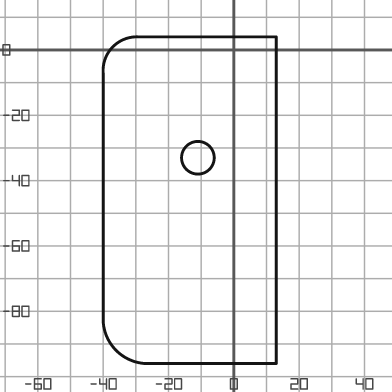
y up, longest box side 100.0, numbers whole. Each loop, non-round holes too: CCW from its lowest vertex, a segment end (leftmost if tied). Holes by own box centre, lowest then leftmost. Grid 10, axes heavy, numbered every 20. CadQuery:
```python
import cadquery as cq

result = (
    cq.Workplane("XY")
    .moveTo(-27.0, -96.0)
    .lineTo(13.0, -96.0)
    .lineTo(13.0, 4.0)
    .lineTo(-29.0, 4.0)
    .threePointArc((-37.0, 1.0), (-40.0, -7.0))
    .lineTo(-40.0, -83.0)
    .threePointArc((-36.0, -92.0), (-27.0, -96.0))
    .close()
    .moveTo(-11.0, -33.0)
    .circle(5.0)
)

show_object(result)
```